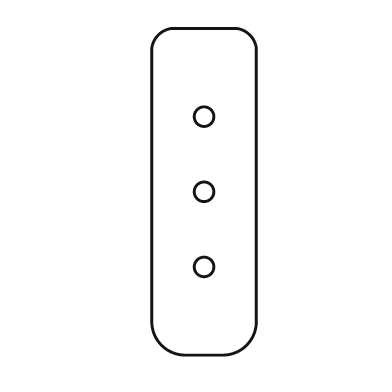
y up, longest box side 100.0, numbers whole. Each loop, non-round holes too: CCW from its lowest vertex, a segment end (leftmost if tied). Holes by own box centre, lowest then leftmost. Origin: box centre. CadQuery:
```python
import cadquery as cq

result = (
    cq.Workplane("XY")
    .moveTo(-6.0, -50.0)
    .lineTo(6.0, -50.0)
    .threePointArc((13.0, -47.0), (16.0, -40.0))
    .lineTo(16.0, 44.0)
    .threePointArc((14.0, 48.0), (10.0, 50.0))
    .lineTo(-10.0, 50.0)
    .threePointArc((-14.0, 48.0), (-16.0, 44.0))
    .lineTo(-16.0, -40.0)
    .threePointArc((-13.0, -47.0), (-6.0, -50.0))
    .close()
    .moveTo(0.0, -23.0)
    .circle(3.0)
    .moveTo(0.0, 0.0)
    .circle(3.0)
    .moveTo(0.0, 23.0)
    .circle(3.0)
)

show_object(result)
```